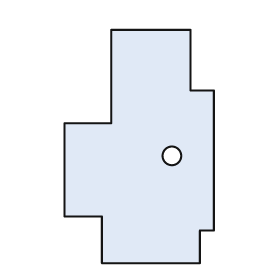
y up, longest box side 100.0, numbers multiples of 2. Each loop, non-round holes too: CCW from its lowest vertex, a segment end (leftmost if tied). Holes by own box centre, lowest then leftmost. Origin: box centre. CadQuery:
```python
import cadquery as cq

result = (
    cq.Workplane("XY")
    .moveTo(-16.0, -50.0)
    .lineTo(26.0, -50.0)
    .lineTo(26.0, -36.0)
    .lineTo(32.0, -36.0)
    .lineTo(32.0, 24.0)
    .lineTo(22.0, 24.0)
    .lineTo(22.0, 50.0)
    .lineTo(-12.0, 50.0)
    .lineTo(-12.0, 10.0)
    .lineTo(-32.0, 10.0)
    .lineTo(-32.0, -30.0)
    .lineTo(-16.0, -30.0)
    .close()
    .moveTo(14.0, -4.0)
    .circle(4.0)
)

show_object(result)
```